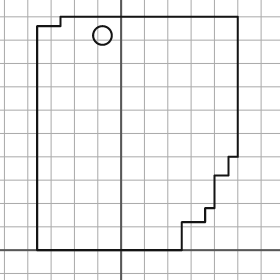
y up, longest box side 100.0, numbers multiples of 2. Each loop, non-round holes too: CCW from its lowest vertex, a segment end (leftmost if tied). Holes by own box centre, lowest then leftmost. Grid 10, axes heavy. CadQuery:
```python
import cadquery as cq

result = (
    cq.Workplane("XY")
    .moveTo(-36.0, 0.0)
    .lineTo(26.0, 0.0)
    .lineTo(26.0, 12.0)
    .lineTo(36.0, 12.0)
    .lineTo(36.0, 18.0)
    .lineTo(40.0, 18.0)
    .lineTo(40.0, 32.0)
    .lineTo(46.0, 32.0)
    .lineTo(46.0, 40.0)
    .lineTo(50.0, 40.0)
    .lineTo(50.0, 100.0)
    .lineTo(-26.0, 100.0)
    .lineTo(-26.0, 96.0)
    .lineTo(-36.0, 96.0)
    .close()
    .moveTo(-8.0, 92.0)
    .circle(4.0)
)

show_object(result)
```